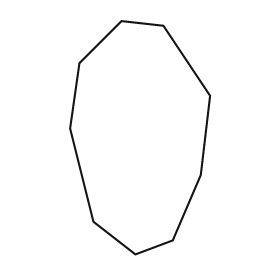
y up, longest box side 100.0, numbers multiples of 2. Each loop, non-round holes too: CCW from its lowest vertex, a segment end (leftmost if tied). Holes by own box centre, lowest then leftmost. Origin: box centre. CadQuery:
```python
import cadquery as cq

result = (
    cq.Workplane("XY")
    .moveTo(-2.0, -50.0)
    .lineTo(14.0, -44.0)
    .lineTo(26.0, -16.0)
    .lineTo(30.0, 18.0)
    .lineTo(10.0, 48.0)
    .lineTo(-8.0, 50.0)
    .lineTo(-26.0, 32.0)
    .lineTo(-30.0, 4.0)
    .lineTo(-20.0, -36.0)
    .close()
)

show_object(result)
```